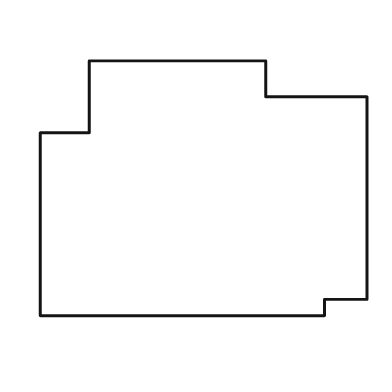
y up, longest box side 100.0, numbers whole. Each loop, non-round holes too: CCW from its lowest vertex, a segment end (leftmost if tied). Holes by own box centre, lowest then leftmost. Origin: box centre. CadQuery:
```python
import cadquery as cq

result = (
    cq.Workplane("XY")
    .moveTo(-50.0, -39.0)
    .lineTo(37.0, -39.0)
    .lineTo(37.0, -34.0)
    .lineTo(50.0, -34.0)
    .lineTo(50.0, 28.0)
    .lineTo(19.0, 28.0)
    .lineTo(19.0, 39.0)
    .lineTo(-35.0, 39.0)
    .lineTo(-35.0, 17.0)
    .lineTo(-50.0, 17.0)
    .close()
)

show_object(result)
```